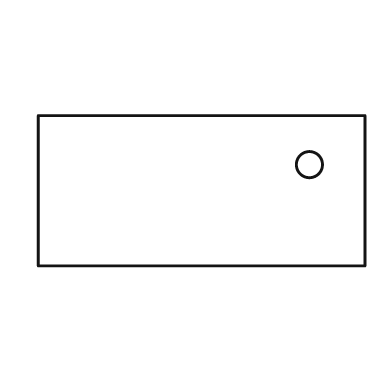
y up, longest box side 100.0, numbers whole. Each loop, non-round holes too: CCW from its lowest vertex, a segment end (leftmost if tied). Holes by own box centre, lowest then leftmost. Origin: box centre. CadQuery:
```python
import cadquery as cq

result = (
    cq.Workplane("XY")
    .moveTo(-50.0, -23.0)
    .lineTo(50.0, -23.0)
    .lineTo(50.0, 23.0)
    .lineTo(-50.0, 23.0)
    .close()
    .moveTo(33.0, 8.0)
    .circle(4.0)
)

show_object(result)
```